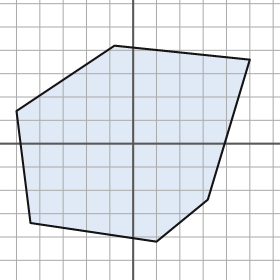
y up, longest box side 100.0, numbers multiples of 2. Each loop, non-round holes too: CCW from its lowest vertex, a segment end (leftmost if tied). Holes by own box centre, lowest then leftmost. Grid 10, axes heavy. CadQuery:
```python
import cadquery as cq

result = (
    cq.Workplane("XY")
    .moveTo(10.0, -42.0)
    .lineTo(32.0, -24.0)
    .lineTo(50.0, 36.0)
    .lineTo(-8.0, 42.0)
    .lineTo(-50.0, 14.0)
    .lineTo(-44.0, -34.0)
    .close()
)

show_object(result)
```